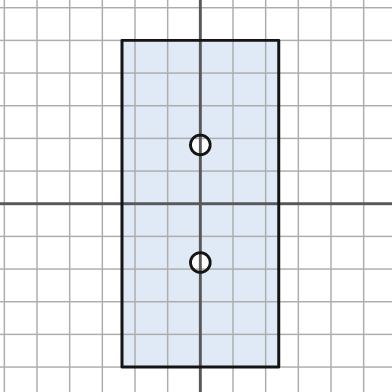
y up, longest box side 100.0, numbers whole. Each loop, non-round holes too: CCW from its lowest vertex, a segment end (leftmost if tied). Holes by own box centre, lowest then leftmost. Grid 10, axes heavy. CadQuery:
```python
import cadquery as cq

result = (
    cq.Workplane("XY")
    .moveTo(-24.0, -50.0)
    .lineTo(24.0, -50.0)
    .lineTo(24.0, 50.0)
    .lineTo(-24.0, 50.0)
    .close()
    .moveTo(0.0, -18.0)
    .circle(3.0)
    .moveTo(0.0, 18.0)
    .circle(3.0)
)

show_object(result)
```